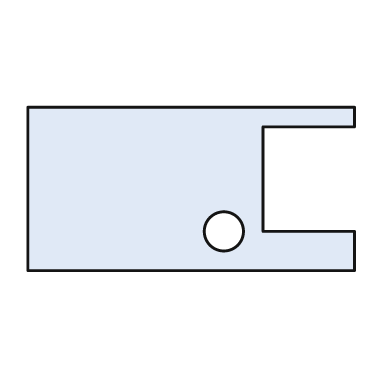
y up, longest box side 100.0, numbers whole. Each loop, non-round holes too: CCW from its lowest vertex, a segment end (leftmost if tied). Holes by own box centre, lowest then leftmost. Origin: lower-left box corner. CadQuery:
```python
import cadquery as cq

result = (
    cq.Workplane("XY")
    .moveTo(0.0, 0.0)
    .lineTo(100.0, 0.0)
    .lineTo(100.0, 12.0)
    .lineTo(72.0, 12.0)
    .lineTo(72.0, 44.0)
    .lineTo(100.0, 44.0)
    .lineTo(100.0, 50.0)
    .lineTo(0.0, 50.0)
    .close()
    .moveTo(60.0, 12.0)
    .circle(6.0)
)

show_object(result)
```